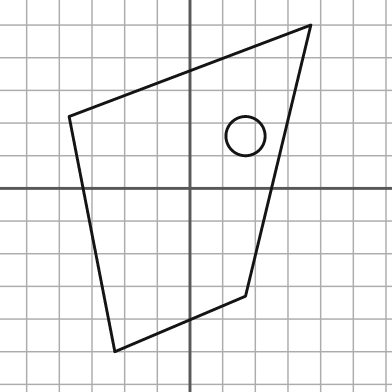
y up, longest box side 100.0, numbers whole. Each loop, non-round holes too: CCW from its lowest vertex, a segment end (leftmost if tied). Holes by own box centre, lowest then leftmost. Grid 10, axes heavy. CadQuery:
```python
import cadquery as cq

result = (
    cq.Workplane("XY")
    .moveTo(-23.0, -50.0)
    .lineTo(17.0, -33.0)
    .lineTo(37.0, 50.0)
    .lineTo(-37.0, 22.0)
    .close()
    .moveTo(17.0, 16.0)
    .circle(6.0)
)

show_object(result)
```